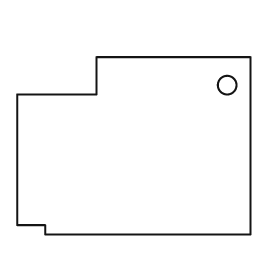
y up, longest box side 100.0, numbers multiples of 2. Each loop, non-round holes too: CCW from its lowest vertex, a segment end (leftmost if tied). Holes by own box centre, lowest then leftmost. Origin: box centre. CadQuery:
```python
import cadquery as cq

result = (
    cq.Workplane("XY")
    .moveTo(-38.0, -38.0)
    .lineTo(50.0, -38.0)
    .lineTo(50.0, 38.0)
    .lineTo(-16.0, 38.0)
    .lineTo(-16.0, 22.0)
    .lineTo(-50.0, 22.0)
    .lineTo(-50.0, -34.0)
    .lineTo(-38.0, -34.0)
    .close()
    .moveTo(40.0, 26.0)
    .circle(4.0)
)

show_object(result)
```